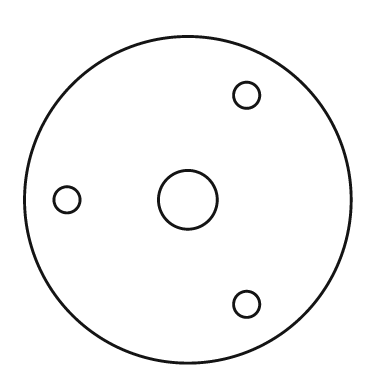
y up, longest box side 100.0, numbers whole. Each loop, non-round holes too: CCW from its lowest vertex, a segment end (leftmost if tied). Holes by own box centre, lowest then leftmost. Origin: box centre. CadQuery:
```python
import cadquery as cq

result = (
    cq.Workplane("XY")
    .moveTo(0.0, 0.0)
    .circle(50.0)
    .moveTo(18.0, -32.0)
    .circle(4.0)
    .moveTo(-37.0, 0.0)
    .circle(4.0)
    .moveTo(0.0, 0.0)
    .circle(9.0)
    .moveTo(18.0, 32.0)
    .circle(4.0)
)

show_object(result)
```